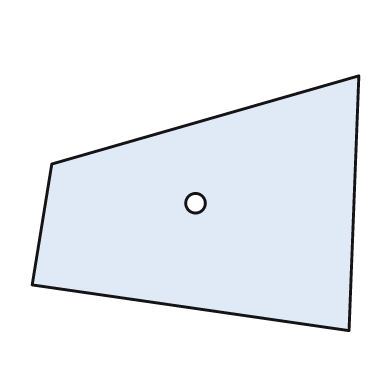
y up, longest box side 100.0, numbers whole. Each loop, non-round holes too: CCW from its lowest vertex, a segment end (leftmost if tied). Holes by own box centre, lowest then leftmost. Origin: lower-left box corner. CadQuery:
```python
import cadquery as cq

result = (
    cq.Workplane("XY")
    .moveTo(97.0, 0.0)
    .lineTo(100.0, 78.0)
    .lineTo(6.0, 51.0)
    .lineTo(0.0, 14.0)
    .close()
    .moveTo(50.0, 39.0)
    .circle(3.0)
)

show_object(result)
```